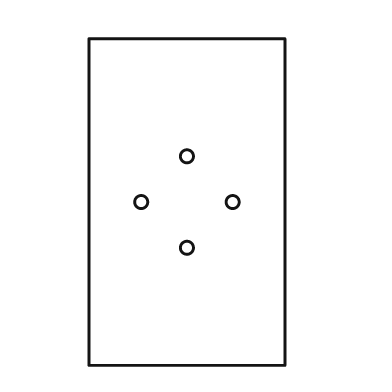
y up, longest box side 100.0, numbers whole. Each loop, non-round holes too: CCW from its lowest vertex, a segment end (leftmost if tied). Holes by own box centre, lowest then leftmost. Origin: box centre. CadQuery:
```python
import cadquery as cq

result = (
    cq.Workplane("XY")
    .moveTo(-30.0, -50.0)
    .lineTo(30.0, -50.0)
    .lineTo(30.0, 50.0)
    .lineTo(-30.0, 50.0)
    .close()
    .moveTo(0.0, -14.0)
    .circle(2.0)
    .moveTo(-14.0, 0.0)
    .circle(2.0)
    .moveTo(14.0, 0.0)
    .circle(2.0)
    .moveTo(0.0, 14.0)
    .circle(2.0)
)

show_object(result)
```